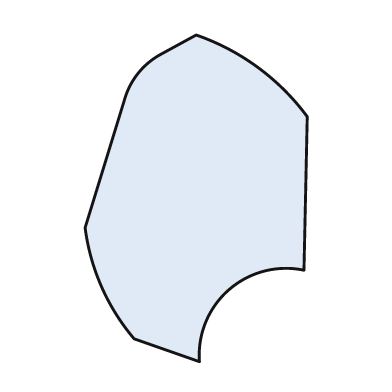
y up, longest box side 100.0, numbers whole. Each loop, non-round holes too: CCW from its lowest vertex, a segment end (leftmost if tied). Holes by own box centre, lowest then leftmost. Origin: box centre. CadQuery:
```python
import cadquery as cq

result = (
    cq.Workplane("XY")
    .moveTo(1.0, -50.0)
    .threePointArc((10.0, -28.0), (33.0, -22.0))
    .lineTo(34.0, 25.0)
    .threePointArc((19.0, 40.0), (0.0, 50.0))
    .lineTo(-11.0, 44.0)
    .threePointArc((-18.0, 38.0), (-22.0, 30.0))
    .lineTo(-34.0, -9.0)
    .threePointArc((-29.0, -27.0), (-19.0, -43.0))
    .close()
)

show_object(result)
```